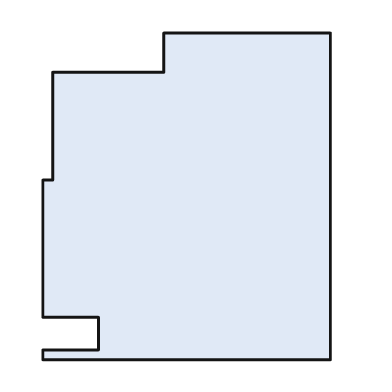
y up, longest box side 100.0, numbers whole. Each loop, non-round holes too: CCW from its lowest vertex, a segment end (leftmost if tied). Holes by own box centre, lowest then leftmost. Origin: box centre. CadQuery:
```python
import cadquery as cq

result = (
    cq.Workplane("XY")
    .moveTo(-44.0, -50.0)
    .lineTo(44.0, -50.0)
    .lineTo(44.0, 50.0)
    .lineTo(-7.0, 50.0)
    .lineTo(-7.0, 38.0)
    .lineTo(-41.0, 38.0)
    .lineTo(-41.0, 5.0)
    .lineTo(-44.0, 5.0)
    .lineTo(-44.0, -37.0)
    .lineTo(-27.0, -37.0)
    .lineTo(-27.0, -47.0)
    .lineTo(-44.0, -47.0)
    .close()
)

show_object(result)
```